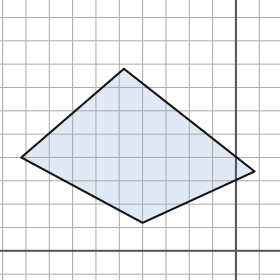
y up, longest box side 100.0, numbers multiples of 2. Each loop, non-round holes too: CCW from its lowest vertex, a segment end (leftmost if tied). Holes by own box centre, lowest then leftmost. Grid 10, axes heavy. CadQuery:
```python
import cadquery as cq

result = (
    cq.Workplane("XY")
    .moveTo(-40.0, 12.0)
    .lineTo(8.0, 34.0)
    .lineTo(-48.0, 78.0)
    .lineTo(-92.0, 40.0)
    .close()
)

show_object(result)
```